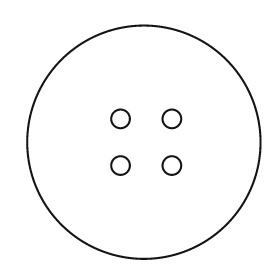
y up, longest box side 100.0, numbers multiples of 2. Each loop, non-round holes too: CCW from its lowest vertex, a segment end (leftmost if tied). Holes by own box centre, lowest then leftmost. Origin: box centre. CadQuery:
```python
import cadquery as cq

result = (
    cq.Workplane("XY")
    .moveTo(0.0, 0.0)
    .circle(50.0)
    .moveTo(-10.0, -10.0)
    .circle(4.0)
    .moveTo(12.0, -10.0)
    .circle(4.0)
    .moveTo(-10.0, 10.0)
    .circle(4.0)
    .moveTo(12.0, 10.0)
    .circle(4.0)
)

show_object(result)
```